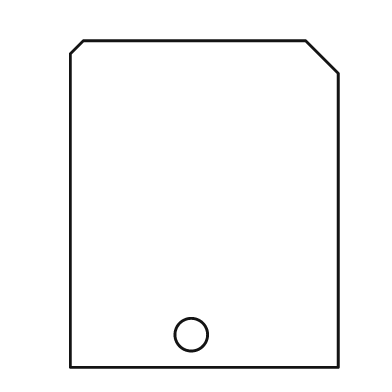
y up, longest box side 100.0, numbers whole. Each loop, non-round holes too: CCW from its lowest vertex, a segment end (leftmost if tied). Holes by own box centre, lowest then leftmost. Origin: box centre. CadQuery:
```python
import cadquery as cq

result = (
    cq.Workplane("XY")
    .moveTo(-41.0, -50.0)
    .lineTo(41.0, -50.0)
    .lineTo(41.0, 40.0)
    .lineTo(31.0, 50.0)
    .lineTo(-37.0, 50.0)
    .lineTo(-41.0, 46.0)
    .close()
    .moveTo(-4.0, -40.0)
    .circle(5.0)
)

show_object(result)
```